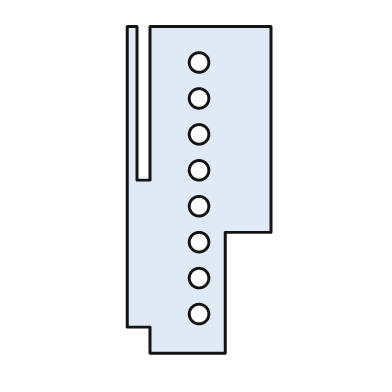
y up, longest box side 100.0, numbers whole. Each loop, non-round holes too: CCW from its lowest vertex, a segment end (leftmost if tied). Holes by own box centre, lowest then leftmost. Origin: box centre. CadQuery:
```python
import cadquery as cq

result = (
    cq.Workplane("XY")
    .moveTo(-15.0, -50.0)
    .lineTo(8.0, -50.0)
    .lineTo(8.0, -13.0)
    .lineTo(22.0, -13.0)
    .lineTo(22.0, 50.0)
    .lineTo(-15.0, 50.0)
    .lineTo(-15.0, 3.0)
    .lineTo(-19.0, 3.0)
    .lineTo(-19.0, 50.0)
    .lineTo(-22.0, 50.0)
    .lineTo(-22.0, -42.0)
    .lineTo(-15.0, -42.0)
    .close()
    .moveTo(0.0, -38.0)
    .circle(3.0)
    .moveTo(0.0, -27.0)
    .circle(3.0)
    .moveTo(0.0, -16.0)
    .circle(3.0)
    .moveTo(0.0, -5.0)
    .circle(3.0)
    .moveTo(0.0, 6.0)
    .circle(3.0)
    .moveTo(0.0, 17.0)
    .circle(3.0)
    .moveTo(0.0, 28.0)
    .circle(3.0)
    .moveTo(0.0, 39.0)
    .circle(3.0)
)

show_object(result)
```